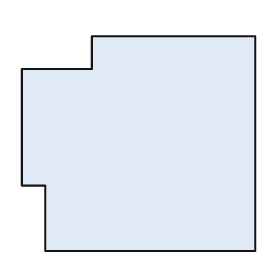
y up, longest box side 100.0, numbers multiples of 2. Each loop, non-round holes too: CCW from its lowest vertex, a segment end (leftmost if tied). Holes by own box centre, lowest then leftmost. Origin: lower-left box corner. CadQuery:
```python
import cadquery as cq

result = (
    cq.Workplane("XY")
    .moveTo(10.0, 0.0)
    .lineTo(100.0, 0.0)
    .lineTo(100.0, 92.0)
    .lineTo(30.0, 92.0)
    .lineTo(30.0, 78.0)
    .lineTo(0.0, 78.0)
    .lineTo(0.0, 28.0)
    .lineTo(10.0, 28.0)
    .close()
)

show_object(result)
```